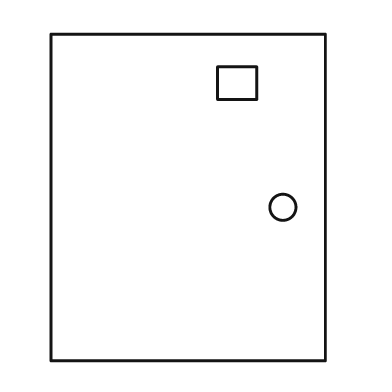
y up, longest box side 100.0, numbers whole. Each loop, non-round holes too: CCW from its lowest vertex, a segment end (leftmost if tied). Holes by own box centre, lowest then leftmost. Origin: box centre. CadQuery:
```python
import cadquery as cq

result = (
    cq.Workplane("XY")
    .moveTo(-42.0, -50.0)
    .lineTo(42.0, -50.0)
    .lineTo(42.0, 50.0)
    .lineTo(-42.0, 50.0)
    .close()
    .moveTo(29.0, -3.0)
    .circle(4.0)
    .moveTo(9.0, 30.0)
    .lineTo(21.0, 30.0)
    .lineTo(21.0, 40.0)
    .lineTo(9.0, 40.0)
    .close()
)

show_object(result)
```